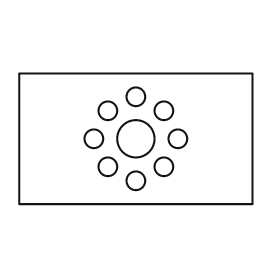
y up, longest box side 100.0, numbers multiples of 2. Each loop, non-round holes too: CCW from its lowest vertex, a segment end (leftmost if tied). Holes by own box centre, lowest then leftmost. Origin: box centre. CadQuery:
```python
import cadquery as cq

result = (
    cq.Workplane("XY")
    .moveTo(-50.0, -28.0)
    .lineTo(50.0, -28.0)
    .lineTo(50.0, 28.0)
    .lineTo(-50.0, 28.0)
    .close()
    .moveTo(0.0, -18.0)
    .circle(4.0)
    .moveTo(-12.0, -12.0)
    .circle(4.0)
    .moveTo(12.0, -12.0)
    .circle(4.0)
    .moveTo(-18.0, 0.0)
    .circle(4.0)
    .moveTo(0.0, 0.0)
    .circle(8.0)
    .moveTo(18.0, 0.0)
    .circle(4.0)
    .moveTo(-12.0, 12.0)
    .circle(4.0)
    .moveTo(12.0, 12.0)
    .circle(4.0)
    .moveTo(0.0, 18.0)
    .circle(4.0)
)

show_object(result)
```